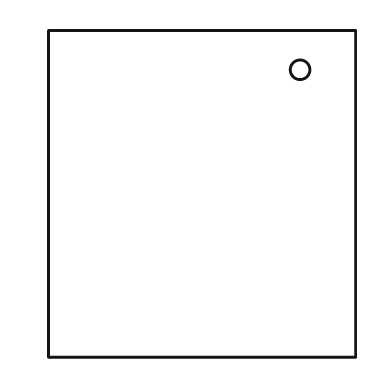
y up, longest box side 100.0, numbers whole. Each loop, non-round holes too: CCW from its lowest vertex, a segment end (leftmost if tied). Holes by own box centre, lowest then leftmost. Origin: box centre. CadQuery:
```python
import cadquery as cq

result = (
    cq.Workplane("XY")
    .moveTo(-47.0, -50.0)
    .lineTo(47.0, -50.0)
    .lineTo(47.0, 50.0)
    .lineTo(-47.0, 50.0)
    .close()
    .moveTo(30.0, 38.0)
    .circle(3.0)
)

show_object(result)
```